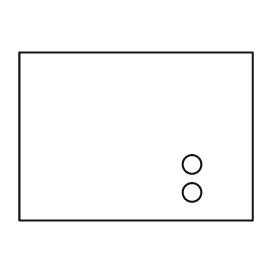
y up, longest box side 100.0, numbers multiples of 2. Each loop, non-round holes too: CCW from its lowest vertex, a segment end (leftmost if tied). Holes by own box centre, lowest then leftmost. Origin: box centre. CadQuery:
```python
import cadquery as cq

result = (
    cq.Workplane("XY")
    .moveTo(-50.0, -36.0)
    .lineTo(50.0, -36.0)
    .lineTo(50.0, 36.0)
    .lineTo(-50.0, 36.0)
    .close()
    .moveTo(24.0, -24.0)
    .circle(4.0)
    .moveTo(24.0, -12.0)
    .circle(4.0)
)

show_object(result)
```